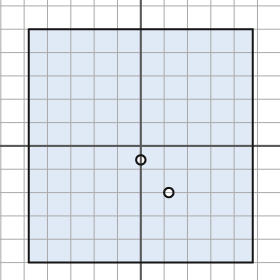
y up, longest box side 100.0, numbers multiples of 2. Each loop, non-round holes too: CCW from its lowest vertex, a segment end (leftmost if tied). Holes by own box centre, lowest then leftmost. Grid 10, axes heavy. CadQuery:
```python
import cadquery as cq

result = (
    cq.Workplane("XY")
    .moveTo(-48.0, -50.0)
    .lineTo(48.0, -50.0)
    .lineTo(48.0, 50.0)
    .lineTo(-48.0, 50.0)
    .close()
    .moveTo(12.0, -20.0)
    .circle(2.0)
    .moveTo(0.0, -6.0)
    .circle(2.0)
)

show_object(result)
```